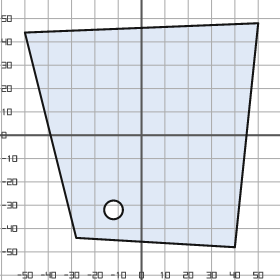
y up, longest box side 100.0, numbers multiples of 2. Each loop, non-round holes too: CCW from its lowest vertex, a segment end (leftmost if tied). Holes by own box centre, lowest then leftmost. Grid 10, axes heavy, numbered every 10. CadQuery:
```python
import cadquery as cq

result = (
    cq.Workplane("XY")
    .moveTo(40.0, -48.0)
    .lineTo(50.0, 48.0)
    .lineTo(-50.0, 44.0)
    .lineTo(-28.0, -44.0)
    .close()
    .moveTo(-12.0, -32.0)
    .circle(4.0)
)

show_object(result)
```